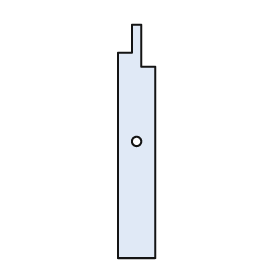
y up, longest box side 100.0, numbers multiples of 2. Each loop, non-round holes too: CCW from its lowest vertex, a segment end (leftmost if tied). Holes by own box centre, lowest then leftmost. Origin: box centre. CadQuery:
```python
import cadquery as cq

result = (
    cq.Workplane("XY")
    .moveTo(-8.0, -50.0)
    .lineTo(8.0, -50.0)
    .lineTo(8.0, 32.0)
    .lineTo(2.0, 32.0)
    .lineTo(2.0, 50.0)
    .lineTo(-2.0, 50.0)
    .lineTo(-2.0, 38.0)
    .lineTo(-8.0, 38.0)
    .close()
    .moveTo(0.0, 0.0)
    .circle(2.0)
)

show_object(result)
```